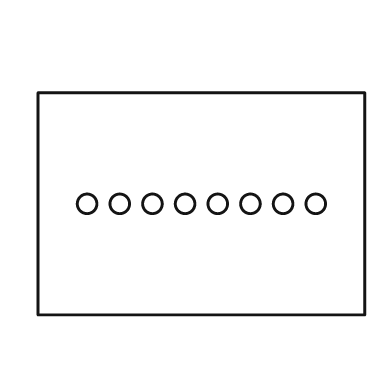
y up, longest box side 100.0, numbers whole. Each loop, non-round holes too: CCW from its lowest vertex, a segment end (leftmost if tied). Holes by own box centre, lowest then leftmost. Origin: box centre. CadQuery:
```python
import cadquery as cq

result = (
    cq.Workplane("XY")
    .moveTo(-50.0, -34.0)
    .lineTo(50.0, -34.0)
    .lineTo(50.0, 34.0)
    .lineTo(-50.0, 34.0)
    .close()
    .moveTo(-35.0, 0.0)
    .circle(3.0)
    .moveTo(-25.0, 0.0)
    .circle(3.0)
    .moveTo(-15.0, 0.0)
    .circle(3.0)
    .moveTo(-5.0, 0.0)
    .circle(3.0)
    .moveTo(5.0, 0.0)
    .circle(3.0)
    .moveTo(15.0, 0.0)
    .circle(3.0)
    .moveTo(25.0, 0.0)
    .circle(3.0)
    .moveTo(35.0, 0.0)
    .circle(3.0)
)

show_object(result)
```